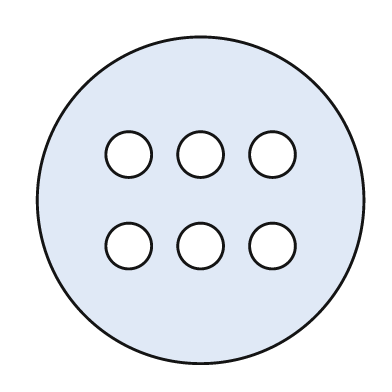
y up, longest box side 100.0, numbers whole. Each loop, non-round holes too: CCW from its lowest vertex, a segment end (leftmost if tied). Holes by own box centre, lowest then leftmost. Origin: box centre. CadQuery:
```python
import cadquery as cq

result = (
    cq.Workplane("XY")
    .moveTo(0.0, 0.0)
    .circle(50.0)
    .moveTo(-22.0, -14.0)
    .circle(7.0)
    .moveTo(0.0, -14.0)
    .circle(7.0)
    .moveTo(22.0, -14.0)
    .circle(7.0)
    .moveTo(-22.0, 14.0)
    .circle(7.0)
    .moveTo(0.0, 14.0)
    .circle(7.0)
    .moveTo(22.0, 14.0)
    .circle(7.0)
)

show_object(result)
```